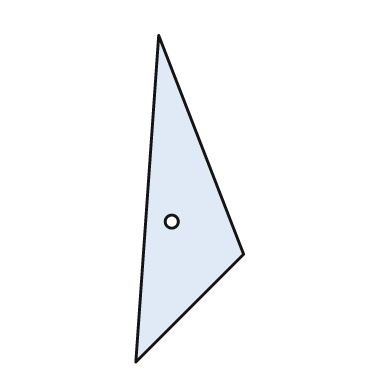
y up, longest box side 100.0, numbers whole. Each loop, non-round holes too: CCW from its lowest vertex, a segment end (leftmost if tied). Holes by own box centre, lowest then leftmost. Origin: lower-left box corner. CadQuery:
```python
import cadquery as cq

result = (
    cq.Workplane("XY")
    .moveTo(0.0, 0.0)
    .lineTo(33.0, 33.0)
    .lineTo(7.0, 100.0)
    .close()
    .moveTo(11.0, 43.0)
    .circle(2.0)
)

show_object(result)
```